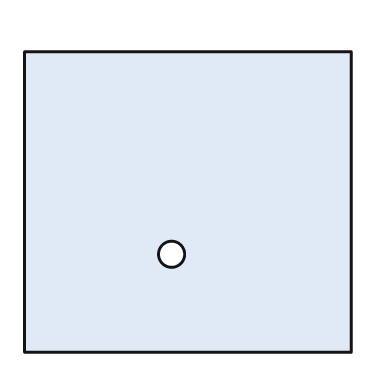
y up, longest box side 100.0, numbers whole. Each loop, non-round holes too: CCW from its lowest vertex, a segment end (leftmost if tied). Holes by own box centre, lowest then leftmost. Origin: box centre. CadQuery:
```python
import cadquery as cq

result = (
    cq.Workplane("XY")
    .moveTo(-50.0, -46.0)
    .lineTo(50.0, -46.0)
    .lineTo(50.0, 46.0)
    .lineTo(-50.0, 46.0)
    .close()
    .moveTo(-5.0, -16.0)
    .circle(4.0)
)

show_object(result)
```